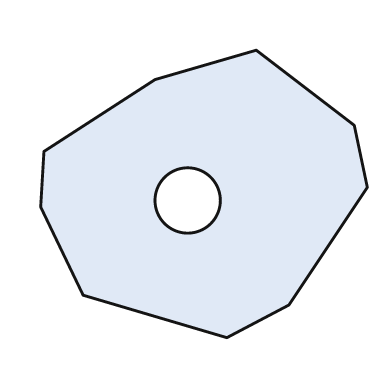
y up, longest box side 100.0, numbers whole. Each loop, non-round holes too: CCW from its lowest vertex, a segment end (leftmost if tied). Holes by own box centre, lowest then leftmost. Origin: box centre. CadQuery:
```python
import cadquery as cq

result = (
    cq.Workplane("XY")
    .moveTo(7.0, -44.0)
    .lineTo(26.0, -34.0)
    .lineTo(50.0, 2.0)
    .lineTo(46.0, 21.0)
    .lineTo(16.0, 44.0)
    .lineTo(-15.0, 35.0)
    .lineTo(-49.0, 13.0)
    .lineTo(-50.0, -4.0)
    .lineTo(-37.0, -31.0)
    .close()
    .moveTo(-5.0, -2.0)
    .circle(10.0)
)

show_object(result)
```